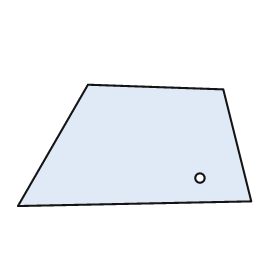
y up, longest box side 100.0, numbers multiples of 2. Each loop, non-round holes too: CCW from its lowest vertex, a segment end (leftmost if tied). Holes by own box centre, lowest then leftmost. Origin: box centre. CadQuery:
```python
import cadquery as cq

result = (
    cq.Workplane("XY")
    .moveTo(-50.0, -26.0)
    .lineTo(50.0, -24.0)
    .lineTo(38.0, 24.0)
    .lineTo(-20.0, 26.0)
    .close()
    .moveTo(28.0, -14.0)
    .circle(2.0)
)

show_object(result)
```